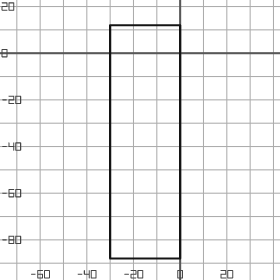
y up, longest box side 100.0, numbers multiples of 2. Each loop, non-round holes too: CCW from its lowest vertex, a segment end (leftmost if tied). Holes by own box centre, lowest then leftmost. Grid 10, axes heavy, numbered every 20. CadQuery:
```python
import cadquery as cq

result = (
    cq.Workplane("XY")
    .moveTo(-30.0, -88.0)
    .lineTo(0.0, -88.0)
    .lineTo(0.0, 12.0)
    .lineTo(-30.0, 12.0)
    .close()
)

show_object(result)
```